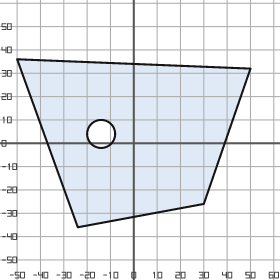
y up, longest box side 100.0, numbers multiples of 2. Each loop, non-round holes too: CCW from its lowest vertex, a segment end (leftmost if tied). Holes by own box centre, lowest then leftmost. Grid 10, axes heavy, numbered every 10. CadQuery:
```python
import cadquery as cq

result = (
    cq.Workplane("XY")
    .moveTo(-24.0, -36.0)
    .lineTo(30.0, -26.0)
    .lineTo(50.0, 32.0)
    .lineTo(-50.0, 36.0)
    .close()
    .moveTo(-14.0, 4.0)
    .circle(6.0)
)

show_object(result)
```